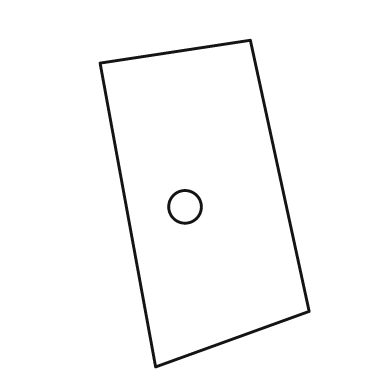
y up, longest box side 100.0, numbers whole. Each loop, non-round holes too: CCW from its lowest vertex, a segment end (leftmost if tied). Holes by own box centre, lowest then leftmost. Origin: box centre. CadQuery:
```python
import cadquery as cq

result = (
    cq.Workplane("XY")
    .moveTo(-15.0, -50.0)
    .lineTo(32.0, -33.0)
    .lineTo(14.0, 50.0)
    .lineTo(-32.0, 43.0)
    .close()
    .moveTo(-6.0, -1.0)
    .circle(5.0)
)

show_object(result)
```